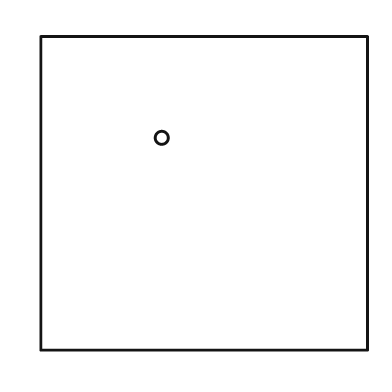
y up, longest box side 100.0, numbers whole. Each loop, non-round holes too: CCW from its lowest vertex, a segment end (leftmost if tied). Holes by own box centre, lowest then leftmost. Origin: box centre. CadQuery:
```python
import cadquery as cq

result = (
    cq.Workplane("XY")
    .moveTo(-50.0, -48.0)
    .lineTo(50.0, -48.0)
    .lineTo(50.0, 48.0)
    .lineTo(-50.0, 48.0)
    .close()
    .moveTo(-13.0, 17.0)
    .circle(2.0)
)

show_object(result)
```